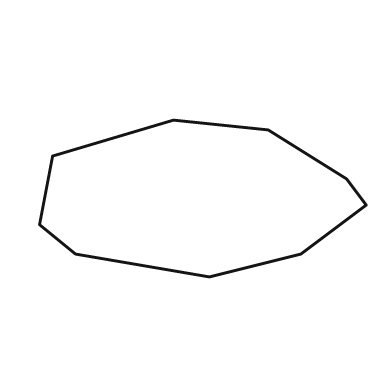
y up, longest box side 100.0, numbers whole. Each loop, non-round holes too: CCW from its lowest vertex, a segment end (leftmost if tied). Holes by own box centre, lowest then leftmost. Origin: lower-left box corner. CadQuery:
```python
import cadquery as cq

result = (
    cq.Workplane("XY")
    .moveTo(52.0, 0.0)
    .lineTo(80.0, 7.0)
    .lineTo(100.0, 22.0)
    .lineTo(94.0, 30.0)
    .lineTo(70.0, 45.0)
    .lineTo(41.0, 48.0)
    .lineTo(4.0, 37.0)
    .lineTo(0.0, 16.0)
    .lineTo(11.0, 7.0)
    .close()
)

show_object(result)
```